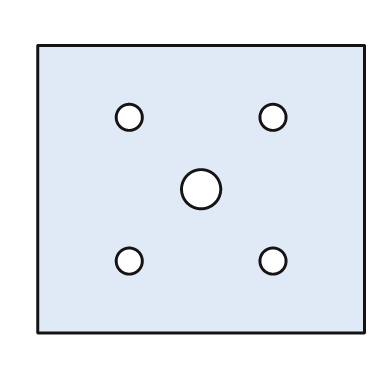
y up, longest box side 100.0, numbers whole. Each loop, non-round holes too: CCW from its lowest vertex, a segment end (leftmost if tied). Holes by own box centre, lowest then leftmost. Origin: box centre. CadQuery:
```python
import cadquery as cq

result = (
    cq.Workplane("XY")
    .moveTo(-50.0, -44.0)
    .lineTo(50.0, -44.0)
    .lineTo(50.0, 44.0)
    .lineTo(-50.0, 44.0)
    .close()
    .moveTo(-22.0, -22.0)
    .circle(4.0)
    .moveTo(22.0, -22.0)
    .circle(4.0)
    .moveTo(0.0, 0.0)
    .circle(6.0)
    .moveTo(-22.0, 22.0)
    .circle(4.0)
    .moveTo(22.0, 22.0)
    .circle(4.0)
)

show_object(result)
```